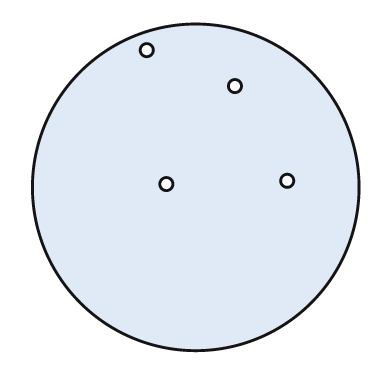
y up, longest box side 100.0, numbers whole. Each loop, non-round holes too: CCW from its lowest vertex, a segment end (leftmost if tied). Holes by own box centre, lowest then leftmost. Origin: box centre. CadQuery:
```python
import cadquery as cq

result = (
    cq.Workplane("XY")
    .moveTo(0.0, 0.0)
    .circle(50.0)
    .moveTo(-9.0, 1.0)
    .circle(2.0)
    .moveTo(28.0, 2.0)
    .circle(2.0)
    .moveTo(12.0, 31.0)
    .circle(2.0)
    .moveTo(-15.0, 42.0)
    .circle(2.0)
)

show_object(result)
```